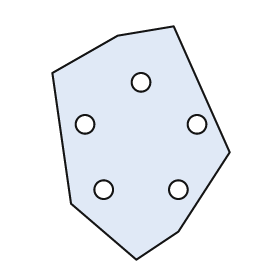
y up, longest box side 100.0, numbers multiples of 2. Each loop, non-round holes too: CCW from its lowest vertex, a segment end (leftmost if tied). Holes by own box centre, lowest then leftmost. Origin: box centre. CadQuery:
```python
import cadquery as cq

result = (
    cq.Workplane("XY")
    .moveTo(-2.0, -50.0)
    .lineTo(16.0, -38.0)
    .lineTo(38.0, -4.0)
    .lineTo(14.0, 50.0)
    .lineTo(-10.0, 46.0)
    .lineTo(-38.0, 30.0)
    .lineTo(-30.0, -26.0)
    .close()
    .moveTo(-16.0, -20.0)
    .circle(4.0)
    .moveTo(16.0, -20.0)
    .circle(4.0)
    .moveTo(-24.0, 8.0)
    .circle(4.0)
    .moveTo(24.0, 8.0)
    .circle(4.0)
    .moveTo(0.0, 26.0)
    .circle(4.0)
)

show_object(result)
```